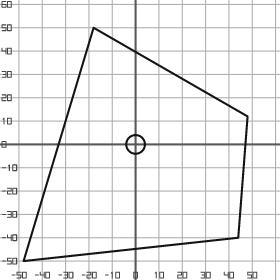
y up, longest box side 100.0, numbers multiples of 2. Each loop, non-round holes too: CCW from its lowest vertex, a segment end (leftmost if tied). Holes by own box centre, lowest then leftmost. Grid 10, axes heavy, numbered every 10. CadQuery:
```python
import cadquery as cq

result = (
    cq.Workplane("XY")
    .moveTo(-48.0, -50.0)
    .lineTo(44.0, -40.0)
    .lineTo(48.0, 12.0)
    .lineTo(-18.0, 50.0)
    .close()
    .moveTo(0.0, 0.0)
    .circle(4.0)
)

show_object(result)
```